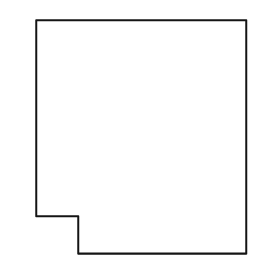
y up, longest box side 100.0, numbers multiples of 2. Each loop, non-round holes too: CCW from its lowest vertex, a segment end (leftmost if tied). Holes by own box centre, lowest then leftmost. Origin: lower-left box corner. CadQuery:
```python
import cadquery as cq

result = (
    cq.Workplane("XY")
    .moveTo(18.0, 0.0)
    .lineTo(90.0, 0.0)
    .lineTo(90.0, 100.0)
    .lineTo(0.0, 100.0)
    .lineTo(0.0, 16.0)
    .lineTo(18.0, 16.0)
    .close()
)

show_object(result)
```